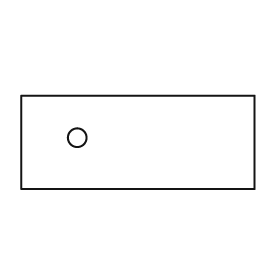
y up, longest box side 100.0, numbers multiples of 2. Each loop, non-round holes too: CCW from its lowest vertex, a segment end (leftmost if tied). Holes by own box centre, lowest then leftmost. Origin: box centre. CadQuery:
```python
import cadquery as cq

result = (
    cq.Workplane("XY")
    .moveTo(-50.0, -20.0)
    .lineTo(50.0, -20.0)
    .lineTo(50.0, 20.0)
    .lineTo(-50.0, 20.0)
    .close()
    .moveTo(-26.0, 2.0)
    .circle(4.0)
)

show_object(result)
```